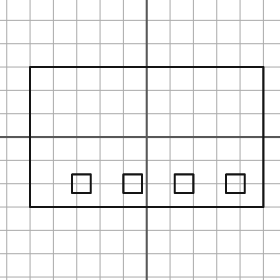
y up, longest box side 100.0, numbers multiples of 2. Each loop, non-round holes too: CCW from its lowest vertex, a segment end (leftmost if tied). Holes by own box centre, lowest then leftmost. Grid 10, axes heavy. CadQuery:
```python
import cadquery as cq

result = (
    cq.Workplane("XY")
    .moveTo(-50.0, -30.0)
    .lineTo(50.0, -30.0)
    .lineTo(50.0, 30.0)
    .lineTo(-50.0, 30.0)
    .close()
    .moveTo(-32.0, -24.0)
    .lineTo(-24.0, -24.0)
    .lineTo(-24.0, -16.0)
    .lineTo(-32.0, -16.0)
    .close()
    .moveTo(-10.0, -24.0)
    .lineTo(-2.0, -24.0)
    .lineTo(-2.0, -16.0)
    .lineTo(-10.0, -16.0)
    .close()
    .moveTo(12.0, -24.0)
    .lineTo(20.0, -24.0)
    .lineTo(20.0, -16.0)
    .lineTo(12.0, -16.0)
    .close()
    .moveTo(34.0, -24.0)
    .lineTo(42.0, -24.0)
    .lineTo(42.0, -16.0)
    .lineTo(34.0, -16.0)
    .close()
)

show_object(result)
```